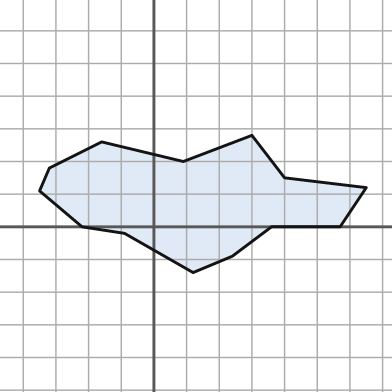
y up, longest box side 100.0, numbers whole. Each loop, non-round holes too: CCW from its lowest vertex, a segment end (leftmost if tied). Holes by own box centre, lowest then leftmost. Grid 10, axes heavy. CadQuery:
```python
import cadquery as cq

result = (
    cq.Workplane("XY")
    .moveTo(12.0, -14.0)
    .lineTo(24.0, -9.0)
    .lineTo(36.0, 0.0)
    .lineTo(57.0, 0.0)
    .lineTo(65.0, 12.0)
    .lineTo(40.0, 15.0)
    .lineTo(30.0, 28.0)
    .lineTo(9.0, 20.0)
    .lineTo(-16.0, 26.0)
    .lineTo(-32.0, 18.0)
    .lineTo(-35.0, 11.0)
    .lineTo(-22.0, 0.0)
    .lineTo(-9.0, -2.0)
    .close()
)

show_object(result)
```